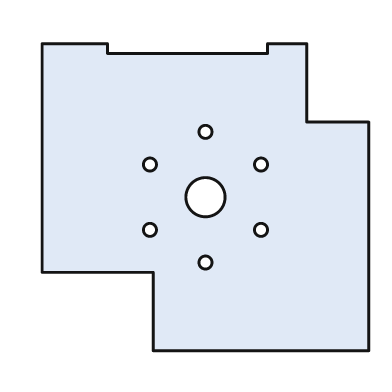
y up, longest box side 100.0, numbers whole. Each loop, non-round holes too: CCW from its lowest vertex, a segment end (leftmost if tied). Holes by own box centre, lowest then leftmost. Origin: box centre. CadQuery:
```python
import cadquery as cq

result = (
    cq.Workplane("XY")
    .moveTo(-16.0, -47.0)
    .lineTo(50.0, -47.0)
    .lineTo(50.0, 23.0)
    .lineTo(31.0, 23.0)
    .lineTo(31.0, 47.0)
    .lineTo(19.0, 47.0)
    .lineTo(19.0, 44.0)
    .lineTo(-30.0, 44.0)
    .lineTo(-30.0, 47.0)
    .lineTo(-50.0, 47.0)
    .lineTo(-50.0, -23.0)
    .lineTo(-16.0, -23.0)
    .close()
    .moveTo(0.0, -20.0)
    .circle(2.0)
    .moveTo(-17.0, -10.0)
    .circle(2.0)
    .moveTo(17.0, -10.0)
    .circle(2.0)
    .moveTo(0.0, 0.0)
    .circle(6.0)
    .moveTo(-17.0, 10.0)
    .circle(2.0)
    .moveTo(17.0, 10.0)
    .circle(2.0)
    .moveTo(0.0, 20.0)
    .circle(2.0)
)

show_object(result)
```